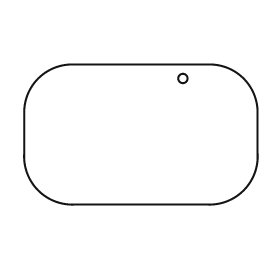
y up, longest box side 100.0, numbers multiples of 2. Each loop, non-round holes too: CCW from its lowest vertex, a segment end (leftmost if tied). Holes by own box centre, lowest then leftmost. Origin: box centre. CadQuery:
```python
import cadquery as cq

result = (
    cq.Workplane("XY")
    .moveTo(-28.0, -30.0)
    .lineTo(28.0, -30.0)
    .threePointArc((44.0, -24.0), (50.0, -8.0))
    .lineTo(50.0, 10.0)
    .threePointArc((44.0, 24.0), (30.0, 30.0))
    .lineTo(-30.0, 30.0)
    .threePointArc((-44.0, 24.0), (-50.0, 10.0))
    .lineTo(-50.0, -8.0)
    .threePointArc((-44.0, -24.0), (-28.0, -30.0))
    .close()
    .moveTo(18.0, 24.0)
    .circle(2.0)
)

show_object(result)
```